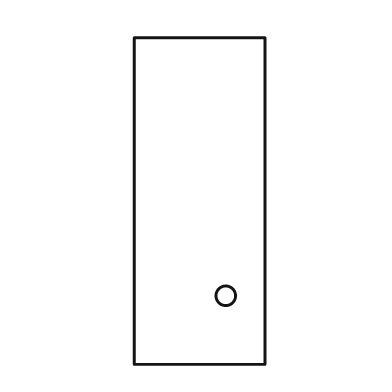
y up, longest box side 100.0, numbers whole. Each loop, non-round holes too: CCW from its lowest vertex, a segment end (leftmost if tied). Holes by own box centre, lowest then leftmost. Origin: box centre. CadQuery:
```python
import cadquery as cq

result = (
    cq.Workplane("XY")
    .moveTo(-20.0, -50.0)
    .lineTo(20.0, -50.0)
    .lineTo(20.0, 50.0)
    .lineTo(-20.0, 50.0)
    .close()
    .moveTo(8.0, -29.0)
    .circle(3.0)
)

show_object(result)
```